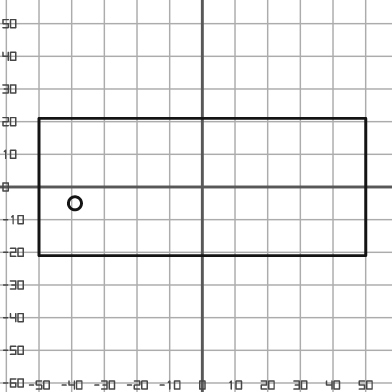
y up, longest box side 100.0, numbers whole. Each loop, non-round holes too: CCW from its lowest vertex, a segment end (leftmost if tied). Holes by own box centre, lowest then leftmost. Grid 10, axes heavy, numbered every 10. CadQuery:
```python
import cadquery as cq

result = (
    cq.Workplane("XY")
    .moveTo(-50.0, -21.0)
    .lineTo(50.0, -21.0)
    .lineTo(50.0, 21.0)
    .lineTo(-50.0, 21.0)
    .close()
    .moveTo(-39.0, -5.0)
    .circle(2.0)
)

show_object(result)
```